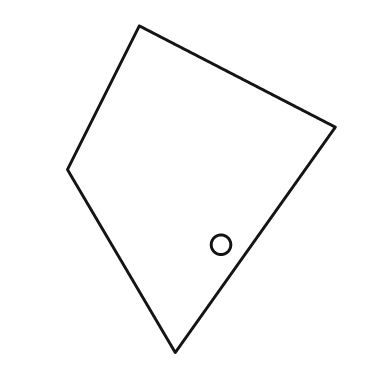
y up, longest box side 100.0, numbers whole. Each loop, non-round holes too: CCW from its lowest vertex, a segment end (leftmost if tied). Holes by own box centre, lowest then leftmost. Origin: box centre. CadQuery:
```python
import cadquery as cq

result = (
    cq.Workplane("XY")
    .moveTo(-8.0, -50.0)
    .lineTo(41.0, 19.0)
    .lineTo(-19.0, 50.0)
    .lineTo(-41.0, 6.0)
    .close()
    .moveTo(6.0, -17.0)
    .circle(3.0)
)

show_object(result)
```